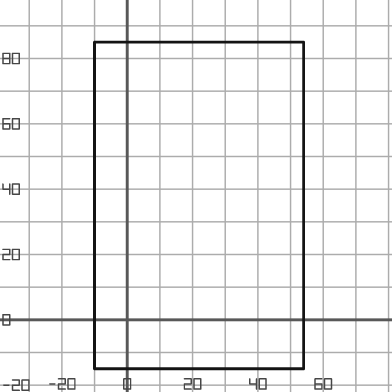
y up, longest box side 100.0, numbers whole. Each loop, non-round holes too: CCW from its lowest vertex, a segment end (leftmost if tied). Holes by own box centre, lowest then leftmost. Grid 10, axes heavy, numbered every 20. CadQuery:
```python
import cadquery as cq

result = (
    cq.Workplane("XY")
    .moveTo(-10.0, -15.0)
    .lineTo(54.0, -15.0)
    .lineTo(54.0, 85.0)
    .lineTo(-10.0, 85.0)
    .close()
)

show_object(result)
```